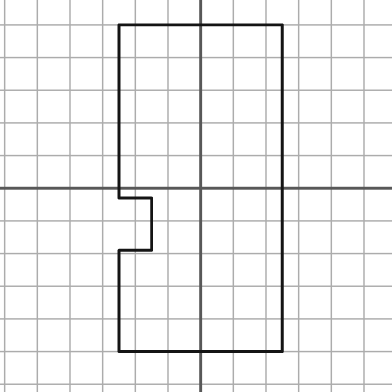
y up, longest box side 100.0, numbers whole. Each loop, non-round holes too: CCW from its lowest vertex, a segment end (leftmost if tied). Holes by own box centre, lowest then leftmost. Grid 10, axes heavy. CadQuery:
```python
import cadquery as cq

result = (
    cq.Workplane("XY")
    .moveTo(-25.0, -50.0)
    .lineTo(25.0, -50.0)
    .lineTo(25.0, 50.0)
    .lineTo(-25.0, 50.0)
    .lineTo(-25.0, -3.0)
    .lineTo(-15.0, -3.0)
    .lineTo(-15.0, -19.0)
    .lineTo(-25.0, -19.0)
    .close()
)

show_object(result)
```